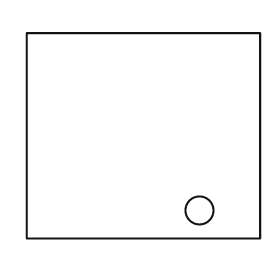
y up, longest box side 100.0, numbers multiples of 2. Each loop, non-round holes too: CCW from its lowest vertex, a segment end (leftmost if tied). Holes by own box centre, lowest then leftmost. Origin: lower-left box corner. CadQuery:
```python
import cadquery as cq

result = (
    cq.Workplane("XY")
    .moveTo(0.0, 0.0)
    .lineTo(100.0, 0.0)
    .lineTo(100.0, 88.0)
    .lineTo(0.0, 88.0)
    .close()
    .moveTo(74.0, 12.0)
    .circle(6.0)
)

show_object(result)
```